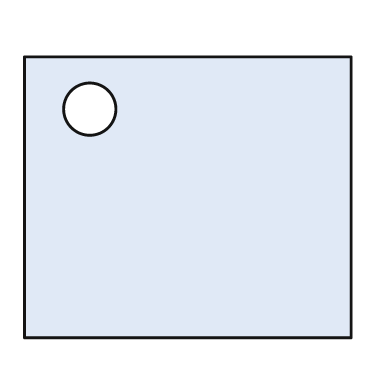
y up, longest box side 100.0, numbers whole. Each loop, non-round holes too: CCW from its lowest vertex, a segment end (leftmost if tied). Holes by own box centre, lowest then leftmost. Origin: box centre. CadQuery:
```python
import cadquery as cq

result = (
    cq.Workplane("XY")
    .moveTo(-50.0, -43.0)
    .lineTo(50.0, -43.0)
    .lineTo(50.0, 43.0)
    .lineTo(-50.0, 43.0)
    .close()
    .moveTo(-30.0, 27.0)
    .circle(8.0)
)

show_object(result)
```